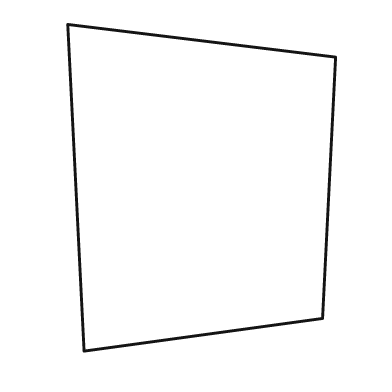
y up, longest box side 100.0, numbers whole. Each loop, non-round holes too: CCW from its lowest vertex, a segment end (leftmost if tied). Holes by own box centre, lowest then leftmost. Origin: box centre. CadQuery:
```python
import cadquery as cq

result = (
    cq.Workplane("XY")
    .moveTo(-36.0, -50.0)
    .lineTo(37.0, -40.0)
    .lineTo(41.0, 40.0)
    .lineTo(-41.0, 50.0)
    .close()
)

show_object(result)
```